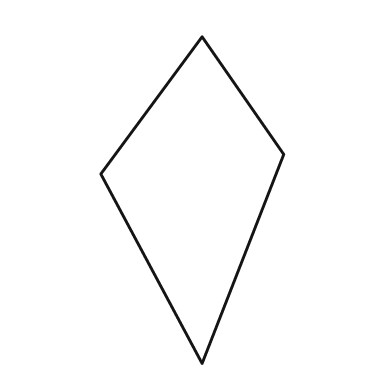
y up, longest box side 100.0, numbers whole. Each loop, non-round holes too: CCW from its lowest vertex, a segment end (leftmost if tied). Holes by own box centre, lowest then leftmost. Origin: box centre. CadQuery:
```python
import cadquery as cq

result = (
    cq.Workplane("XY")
    .moveTo(3.0, -50.0)
    .lineTo(28.0, 14.0)
    .lineTo(3.0, 50.0)
    .lineTo(-28.0, 8.0)
    .close()
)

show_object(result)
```